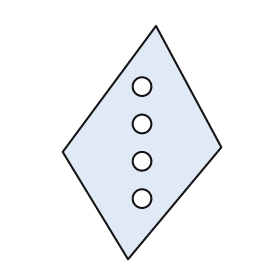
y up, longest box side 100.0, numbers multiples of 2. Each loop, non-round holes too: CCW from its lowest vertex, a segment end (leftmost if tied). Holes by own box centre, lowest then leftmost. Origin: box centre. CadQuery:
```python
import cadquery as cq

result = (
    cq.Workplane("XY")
    .moveTo(-6.0, -50.0)
    .lineTo(34.0, -2.0)
    .lineTo(6.0, 50.0)
    .lineTo(-34.0, -4.0)
    .close()
    .moveTo(0.0, -24.0)
    .circle(4.0)
    .moveTo(0.0, -8.0)
    .circle(4.0)
    .moveTo(0.0, 8.0)
    .circle(4.0)
    .moveTo(0.0, 24.0)
    .circle(4.0)
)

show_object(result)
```